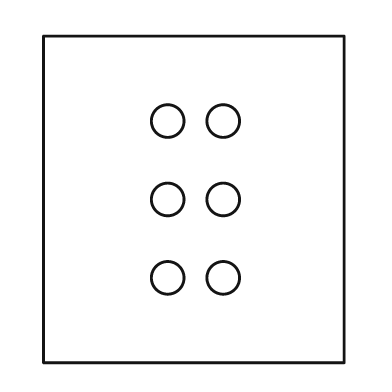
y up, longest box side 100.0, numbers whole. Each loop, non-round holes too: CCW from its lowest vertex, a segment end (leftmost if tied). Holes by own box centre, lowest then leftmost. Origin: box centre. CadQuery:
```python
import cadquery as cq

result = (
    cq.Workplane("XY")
    .moveTo(-46.0, -50.0)
    .lineTo(46.0, -50.0)
    .lineTo(46.0, 50.0)
    .lineTo(-46.0, 50.0)
    .close()
    .moveTo(-8.0, -24.0)
    .circle(5.0)
    .moveTo(9.0, -24.0)
    .circle(5.0)
    .moveTo(-8.0, 0.0)
    .circle(5.0)
    .moveTo(9.0, 0.0)
    .circle(5.0)
    .moveTo(-8.0, 24.0)
    .circle(5.0)
    .moveTo(9.0, 24.0)
    .circle(5.0)
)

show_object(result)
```